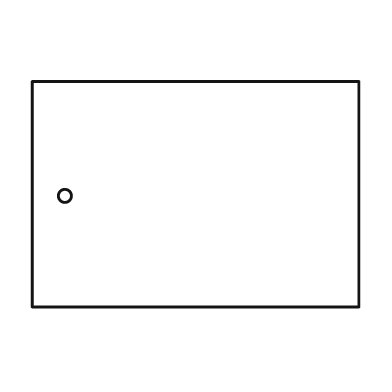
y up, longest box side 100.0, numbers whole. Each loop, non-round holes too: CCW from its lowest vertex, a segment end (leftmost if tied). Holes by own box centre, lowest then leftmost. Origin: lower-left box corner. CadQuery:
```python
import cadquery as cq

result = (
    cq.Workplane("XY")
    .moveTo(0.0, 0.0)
    .lineTo(100.0, 0.0)
    .lineTo(100.0, 69.0)
    .lineTo(0.0, 69.0)
    .close()
    .moveTo(10.0, 34.0)
    .circle(2.0)
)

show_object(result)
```